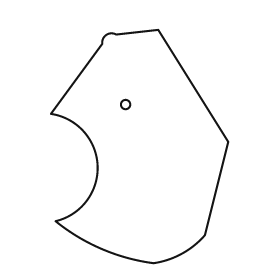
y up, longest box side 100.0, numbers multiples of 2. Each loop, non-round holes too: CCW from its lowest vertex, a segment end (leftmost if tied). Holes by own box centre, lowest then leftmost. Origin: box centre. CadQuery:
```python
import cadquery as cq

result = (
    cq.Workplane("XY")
    .moveTo(6.0, -50.0)
    .threePointArc((18.0, -46.0), (28.0, -38.0))
    .lineTo(38.0, 2.0)
    .lineTo(8.0, 50.0)
    .lineTo(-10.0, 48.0)
    .threePointArc((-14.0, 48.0), (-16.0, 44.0))
    .lineTo(-38.0, 14.0)
    .threePointArc((-18.0, -8.0), (-36.0, -32.0))
    .threePointArc((-16.0, -44.0), (6.0, -50.0))
    .close()
    .moveTo(-6.0, 18.0)
    .circle(2.0)
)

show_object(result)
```